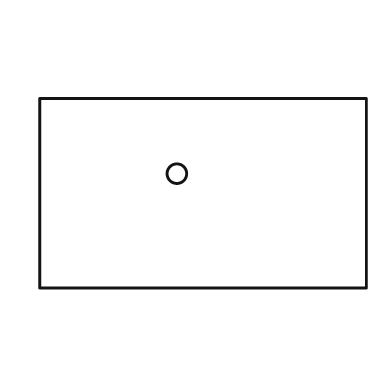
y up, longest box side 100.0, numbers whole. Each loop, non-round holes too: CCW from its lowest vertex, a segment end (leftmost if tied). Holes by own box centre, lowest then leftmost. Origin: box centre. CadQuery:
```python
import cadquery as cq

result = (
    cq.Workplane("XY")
    .moveTo(-50.0, -29.0)
    .lineTo(50.0, -29.0)
    .lineTo(50.0, 29.0)
    .lineTo(-50.0, 29.0)
    .close()
    .moveTo(-8.0, 6.0)
    .circle(3.0)
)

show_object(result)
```